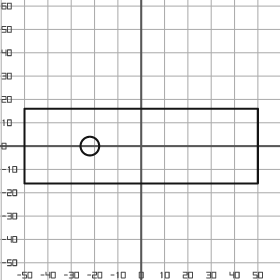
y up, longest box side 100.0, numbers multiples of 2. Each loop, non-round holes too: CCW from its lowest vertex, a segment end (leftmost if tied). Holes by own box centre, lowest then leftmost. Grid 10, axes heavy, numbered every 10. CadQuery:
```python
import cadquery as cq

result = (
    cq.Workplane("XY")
    .moveTo(-50.0, -16.0)
    .lineTo(50.0, -16.0)
    .lineTo(50.0, 16.0)
    .lineTo(-50.0, 16.0)
    .close()
    .moveTo(-22.0, 0.0)
    .circle(4.0)
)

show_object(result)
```